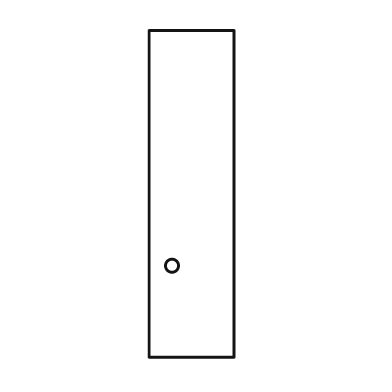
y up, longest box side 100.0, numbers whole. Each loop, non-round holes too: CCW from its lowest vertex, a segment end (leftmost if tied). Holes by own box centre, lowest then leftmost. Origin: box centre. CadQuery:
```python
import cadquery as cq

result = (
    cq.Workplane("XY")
    .moveTo(-13.0, -50.0)
    .lineTo(13.0, -50.0)
    .lineTo(13.0, 50.0)
    .lineTo(-13.0, 50.0)
    .close()
    .moveTo(-6.0, -22.0)
    .circle(2.0)
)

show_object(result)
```